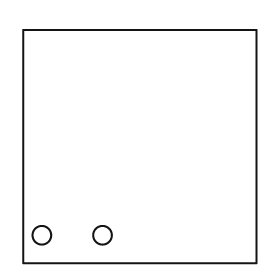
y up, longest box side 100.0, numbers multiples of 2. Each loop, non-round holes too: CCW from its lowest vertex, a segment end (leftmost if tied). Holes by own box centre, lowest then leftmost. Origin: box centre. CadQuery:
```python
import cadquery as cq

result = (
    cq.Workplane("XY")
    .moveTo(-50.0, -50.0)
    .lineTo(50.0, -50.0)
    .lineTo(50.0, 50.0)
    .lineTo(-50.0, 50.0)
    .close()
    .moveTo(-42.0, -38.0)
    .circle(4.0)
    .moveTo(-16.0, -38.0)
    .circle(4.0)
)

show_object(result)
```